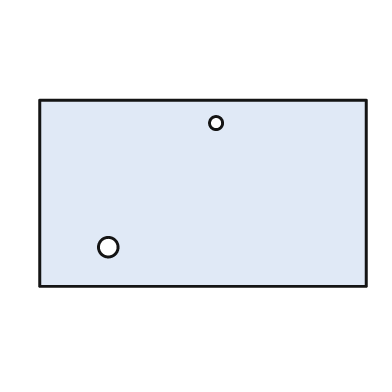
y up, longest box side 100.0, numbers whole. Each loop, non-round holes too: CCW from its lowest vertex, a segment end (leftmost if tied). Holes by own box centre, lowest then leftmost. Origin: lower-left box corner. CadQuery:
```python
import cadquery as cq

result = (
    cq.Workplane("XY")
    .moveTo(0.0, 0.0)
    .lineTo(100.0, 0.0)
    .lineTo(100.0, 57.0)
    .lineTo(0.0, 57.0)
    .close()
    .moveTo(21.0, 12.0)
    .circle(3.0)
    .moveTo(54.0, 50.0)
    .circle(2.0)
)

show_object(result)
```